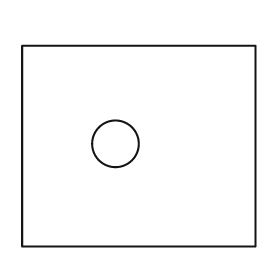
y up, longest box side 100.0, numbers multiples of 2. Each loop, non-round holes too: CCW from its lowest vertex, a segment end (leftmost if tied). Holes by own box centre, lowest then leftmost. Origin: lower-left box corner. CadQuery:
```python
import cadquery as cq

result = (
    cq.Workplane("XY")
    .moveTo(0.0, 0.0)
    .lineTo(100.0, 0.0)
    .lineTo(100.0, 86.0)
    .lineTo(0.0, 86.0)
    .close()
    .moveTo(40.0, 44.0)
    .circle(10.0)
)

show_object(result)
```